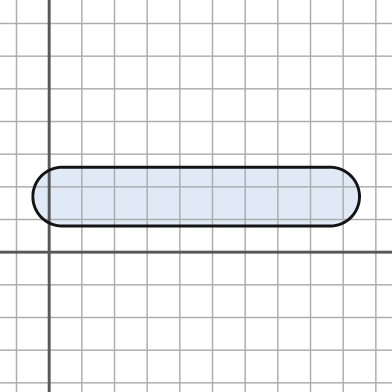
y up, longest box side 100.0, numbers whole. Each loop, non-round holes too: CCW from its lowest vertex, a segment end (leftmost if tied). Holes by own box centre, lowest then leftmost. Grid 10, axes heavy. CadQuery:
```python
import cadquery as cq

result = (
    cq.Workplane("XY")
    .moveTo(4.0, 8.0)
    .lineTo(86.0, 8.0)
    .threePointArc((95.0, 17.0), (86.0, 26.0))
    .lineTo(4.0, 26.0)
    .threePointArc((-5.0, 17.0), (4.0, 8.0))
    .close()
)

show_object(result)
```